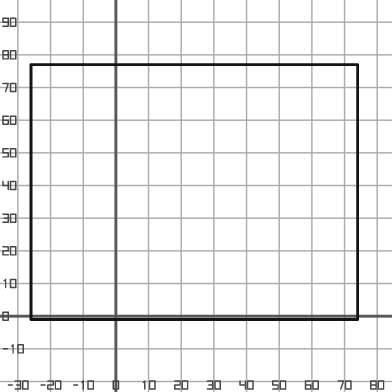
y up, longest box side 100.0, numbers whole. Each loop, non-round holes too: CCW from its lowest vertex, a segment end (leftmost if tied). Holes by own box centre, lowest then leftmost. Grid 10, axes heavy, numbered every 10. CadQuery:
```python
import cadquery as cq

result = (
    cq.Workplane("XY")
    .moveTo(-26.0, -1.0)
    .lineTo(74.0, -1.0)
    .lineTo(74.0, 77.0)
    .lineTo(-26.0, 77.0)
    .close()
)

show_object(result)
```